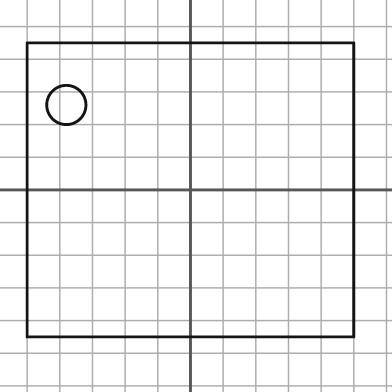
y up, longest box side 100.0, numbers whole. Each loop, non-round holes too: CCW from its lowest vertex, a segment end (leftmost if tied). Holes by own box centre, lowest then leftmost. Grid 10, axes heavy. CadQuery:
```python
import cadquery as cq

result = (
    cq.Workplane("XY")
    .moveTo(-50.0, -45.0)
    .lineTo(50.0, -45.0)
    .lineTo(50.0, 45.0)
    .lineTo(-50.0, 45.0)
    .close()
    .moveTo(-38.0, 26.0)
    .circle(6.0)
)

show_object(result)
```